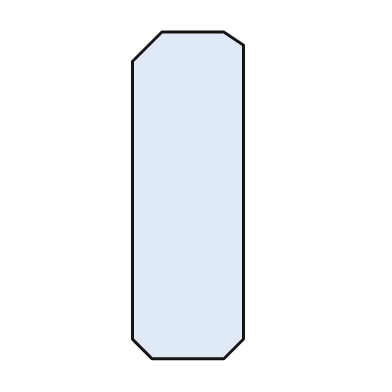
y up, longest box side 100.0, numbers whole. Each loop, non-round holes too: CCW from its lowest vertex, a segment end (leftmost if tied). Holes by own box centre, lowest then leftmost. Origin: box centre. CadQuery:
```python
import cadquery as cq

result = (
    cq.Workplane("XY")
    .moveTo(-11.0, -50.0)
    .lineTo(11.0, -50.0)
    .lineTo(17.0, -44.0)
    .lineTo(17.0, 46.0)
    .lineTo(11.0, 50.0)
    .lineTo(-8.0, 50.0)
    .lineTo(-17.0, 41.0)
    .lineTo(-17.0, -44.0)
    .close()
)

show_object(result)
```